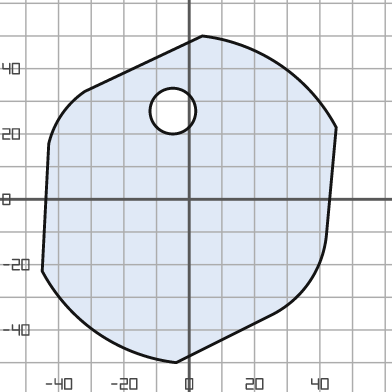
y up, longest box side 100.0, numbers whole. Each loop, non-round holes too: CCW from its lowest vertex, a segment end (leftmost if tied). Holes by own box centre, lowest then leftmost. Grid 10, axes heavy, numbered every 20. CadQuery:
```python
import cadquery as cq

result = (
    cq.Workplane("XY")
    .moveTo(-4.0, -50.0)
    .lineTo(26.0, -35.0)
    .threePointArc((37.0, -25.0), (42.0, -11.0))
    .lineTo(45.0, 22.0)
    .threePointArc((28.0, 41.0), (4.0, 50.0))
    .lineTo(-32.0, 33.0)
    .threePointArc((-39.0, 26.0), (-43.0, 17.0))
    .lineTo(-45.0, -22.0)
    .threePointArc((-28.0, -41.0), (-4.0, -50.0))
    .close()
    .moveTo(-5.0, 27.0)
    .circle(7.0)
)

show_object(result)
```